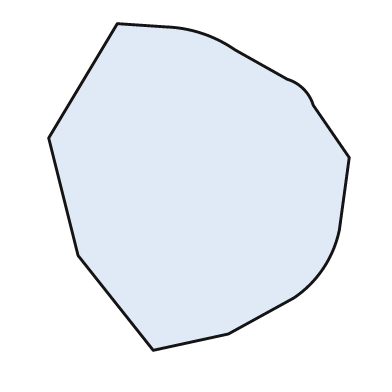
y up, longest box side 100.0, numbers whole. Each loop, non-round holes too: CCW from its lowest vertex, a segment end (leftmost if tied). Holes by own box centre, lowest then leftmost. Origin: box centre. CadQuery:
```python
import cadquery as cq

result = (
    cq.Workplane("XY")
    .moveTo(-14.0, -50.0)
    .lineTo(9.0, -45.0)
    .lineTo(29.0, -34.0)
    .threePointArc((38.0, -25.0), (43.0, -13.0))
    .lineTo(46.0, 9.0)
    .lineTo(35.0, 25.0)
    .threePointArc((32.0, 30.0), (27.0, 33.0))
    .lineTo(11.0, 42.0)
    .threePointArc((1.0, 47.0), (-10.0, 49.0))
    .lineTo(-25.0, 50.0)
    .lineTo(-46.0, 15.0)
    .lineTo(-37.0, -21.0)
    .close()
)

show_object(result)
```